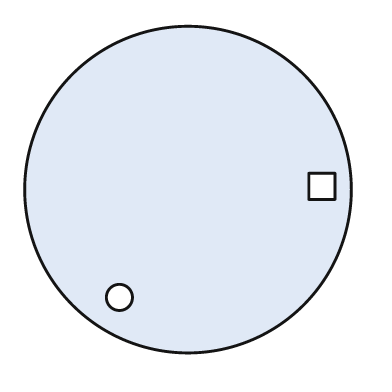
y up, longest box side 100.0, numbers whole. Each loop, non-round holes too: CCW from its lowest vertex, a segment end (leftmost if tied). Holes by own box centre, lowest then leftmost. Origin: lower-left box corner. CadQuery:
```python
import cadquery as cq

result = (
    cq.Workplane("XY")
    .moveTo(50.0, 50.0)
    .circle(50.0)
    .moveTo(29.0, 17.0)
    .circle(4.0)
    .moveTo(87.0, 47.0)
    .lineTo(95.0, 47.0)
    .lineTo(95.0, 55.0)
    .lineTo(87.0, 55.0)
    .close()
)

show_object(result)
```